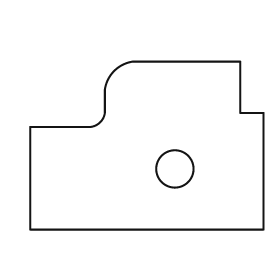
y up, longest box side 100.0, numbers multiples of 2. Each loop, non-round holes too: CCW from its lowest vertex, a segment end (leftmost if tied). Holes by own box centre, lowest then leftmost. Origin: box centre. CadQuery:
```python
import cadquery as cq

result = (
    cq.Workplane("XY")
    .moveTo(-50.0, -36.0)
    .lineTo(50.0, -36.0)
    .lineTo(50.0, 14.0)
    .lineTo(40.0, 14.0)
    .lineTo(40.0, 36.0)
    .lineTo(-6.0, 36.0)
    .threePointArc((-14.0, 32.0), (-18.0, 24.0))
    .lineTo(-18.0, 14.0)
    .threePointArc((-20.0, 10.0), (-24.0, 8.0))
    .lineTo(-50.0, 8.0)
    .close()
    .moveTo(12.0, -10.0)
    .circle(8.0)
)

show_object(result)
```